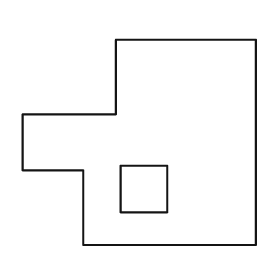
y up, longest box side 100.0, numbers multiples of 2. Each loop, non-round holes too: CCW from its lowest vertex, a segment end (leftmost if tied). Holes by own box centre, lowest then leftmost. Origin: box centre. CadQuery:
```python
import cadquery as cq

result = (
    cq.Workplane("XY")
    .moveTo(-24.0, -44.0)
    .lineTo(50.0, -44.0)
    .lineTo(50.0, 44.0)
    .lineTo(-10.0, 44.0)
    .lineTo(-10.0, 12.0)
    .lineTo(-50.0, 12.0)
    .lineTo(-50.0, -12.0)
    .lineTo(-24.0, -12.0)
    .close()
    .moveTo(-8.0, -30.0)
    .lineTo(12.0, -30.0)
    .lineTo(12.0, -10.0)
    .lineTo(-8.0, -10.0)
    .close()
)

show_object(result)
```